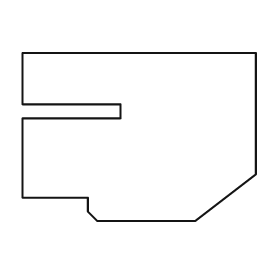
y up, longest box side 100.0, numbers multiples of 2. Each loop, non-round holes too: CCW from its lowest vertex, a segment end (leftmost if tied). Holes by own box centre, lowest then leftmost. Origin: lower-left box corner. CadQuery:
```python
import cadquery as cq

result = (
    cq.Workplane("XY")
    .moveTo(32.0, 0.0)
    .lineTo(74.0, 0.0)
    .lineTo(100.0, 20.0)
    .lineTo(100.0, 72.0)
    .lineTo(0.0, 72.0)
    .lineTo(0.0, 50.0)
    .lineTo(42.0, 50.0)
    .lineTo(42.0, 44.0)
    .lineTo(0.0, 44.0)
    .lineTo(0.0, 10.0)
    .lineTo(28.0, 10.0)
    .lineTo(28.0, 4.0)
    .close()
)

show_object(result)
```